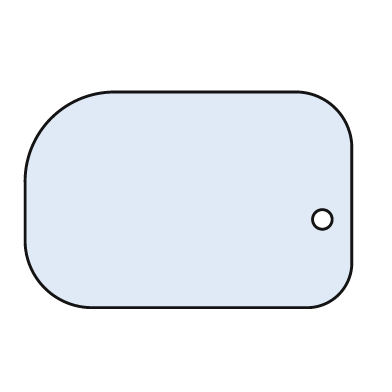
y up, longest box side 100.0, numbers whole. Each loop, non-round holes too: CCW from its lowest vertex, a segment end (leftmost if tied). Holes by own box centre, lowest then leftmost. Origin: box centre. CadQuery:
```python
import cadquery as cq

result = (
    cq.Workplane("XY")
    .moveTo(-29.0, -33.0)
    .lineTo(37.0, -33.0)
    .threePointArc((46.0, -29.0), (50.0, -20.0))
    .lineTo(50.0, 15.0)
    .threePointArc((45.0, 28.0), (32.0, 33.0))
    .lineTo(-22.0, 33.0)
    .threePointArc((-42.0, 25.0), (-50.0, 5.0))
    .lineTo(-50.0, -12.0)
    .threePointArc((-44.0, -27.0), (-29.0, -33.0))
    .close()
    .moveTo(41.0, -6.0)
    .circle(3.0)
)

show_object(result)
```